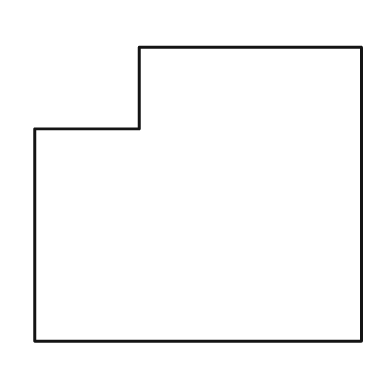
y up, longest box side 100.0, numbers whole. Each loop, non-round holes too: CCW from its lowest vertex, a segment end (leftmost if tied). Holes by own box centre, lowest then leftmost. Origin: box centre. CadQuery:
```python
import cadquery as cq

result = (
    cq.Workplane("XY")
    .moveTo(-50.0, -45.0)
    .lineTo(50.0, -45.0)
    .lineTo(50.0, 45.0)
    .lineTo(-18.0, 45.0)
    .lineTo(-18.0, 20.0)
    .lineTo(-50.0, 20.0)
    .close()
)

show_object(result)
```